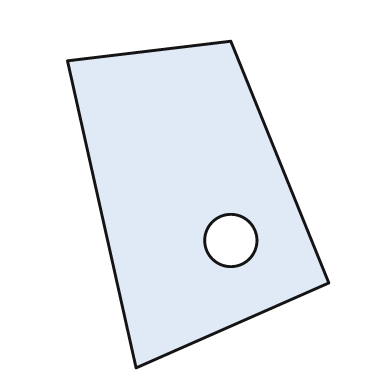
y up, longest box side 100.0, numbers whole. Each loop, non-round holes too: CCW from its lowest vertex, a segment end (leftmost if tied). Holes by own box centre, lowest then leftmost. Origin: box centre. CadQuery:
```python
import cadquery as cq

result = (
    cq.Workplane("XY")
    .moveTo(-19.0, -50.0)
    .lineTo(40.0, -24.0)
    .lineTo(10.0, 50.0)
    .lineTo(-40.0, 44.0)
    .close()
    .moveTo(10.0, -11.0)
    .circle(8.0)
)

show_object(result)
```